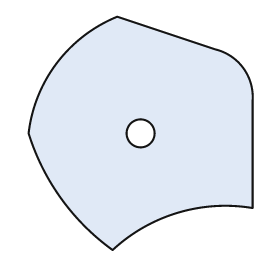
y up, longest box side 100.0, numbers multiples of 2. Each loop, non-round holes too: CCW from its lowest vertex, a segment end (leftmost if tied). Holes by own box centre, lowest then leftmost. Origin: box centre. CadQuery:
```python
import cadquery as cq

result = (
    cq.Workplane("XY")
    .moveTo(-12.0, -50.0)
    .threePointArc((16.0, -34.0), (48.0, -32.0))
    .lineTo(48.0, 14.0)
    .threePointArc((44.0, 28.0), (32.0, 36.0))
    .lineTo(-10.0, 50.0)
    .threePointArc((-36.0, 30.0), (-48.0, 0.0))
    .threePointArc((-34.0, -28.0), (-12.0, -50.0))
    .close()
    .moveTo(0.0, 0.0)
    .circle(6.0)
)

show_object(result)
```